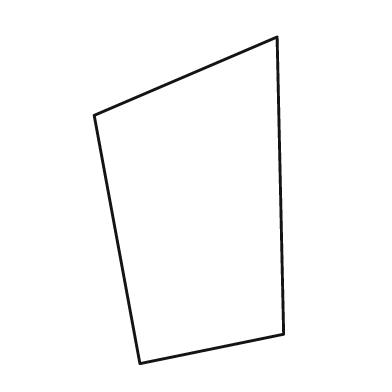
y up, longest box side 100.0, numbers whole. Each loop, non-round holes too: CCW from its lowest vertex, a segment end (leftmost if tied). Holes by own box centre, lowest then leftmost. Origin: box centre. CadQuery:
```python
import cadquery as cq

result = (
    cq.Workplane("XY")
    .moveTo(-15.0, -50.0)
    .lineTo(29.0, -41.0)
    .lineTo(27.0, 50.0)
    .lineTo(-29.0, 26.0)
    .close()
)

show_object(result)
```